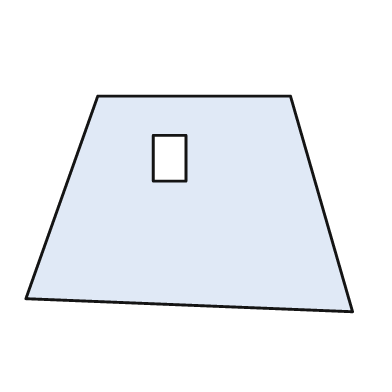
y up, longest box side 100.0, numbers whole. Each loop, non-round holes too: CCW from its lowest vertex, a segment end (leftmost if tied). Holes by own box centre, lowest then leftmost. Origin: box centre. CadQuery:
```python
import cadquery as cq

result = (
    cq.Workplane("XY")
    .moveTo(50.0, -33.0)
    .lineTo(31.0, 33.0)
    .lineTo(-28.0, 33.0)
    .lineTo(-50.0, -29.0)
    .close()
    .moveTo(-11.0, 7.0)
    .lineTo(-1.0, 7.0)
    .lineTo(-1.0, 21.0)
    .lineTo(-11.0, 21.0)
    .close()
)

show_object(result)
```